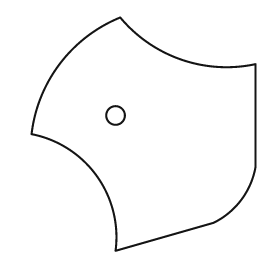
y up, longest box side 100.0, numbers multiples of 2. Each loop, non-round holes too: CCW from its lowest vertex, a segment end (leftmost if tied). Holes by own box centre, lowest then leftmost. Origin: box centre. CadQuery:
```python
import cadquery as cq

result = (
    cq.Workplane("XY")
    .moveTo(-12.0, -50.0)
    .lineTo(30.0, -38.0)
    .threePointArc((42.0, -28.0), (48.0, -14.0))
    .lineTo(48.0, 30.0)
    .threePointArc((16.0, 32.0), (-10.0, 50.0))
    .threePointArc((-36.0, 30.0), (-48.0, 0.0))
    .threePointArc((-20.0, -18.0), (-12.0, -50.0))
    .close()
    .moveTo(-12.0, 8.0)
    .circle(4.0)
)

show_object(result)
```